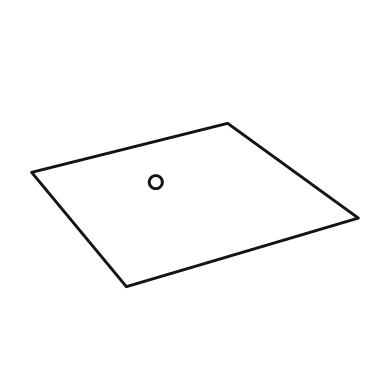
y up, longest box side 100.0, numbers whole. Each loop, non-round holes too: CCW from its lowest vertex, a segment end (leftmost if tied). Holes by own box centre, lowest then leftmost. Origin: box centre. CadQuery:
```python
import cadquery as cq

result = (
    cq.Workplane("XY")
    .moveTo(-21.0, -25.0)
    .lineTo(50.0, -4.0)
    .lineTo(10.0, 25.0)
    .lineTo(-50.0, 10.0)
    .close()
    .moveTo(-12.0, 7.0)
    .circle(2.0)
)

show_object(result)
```